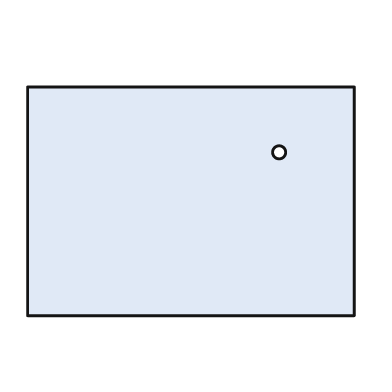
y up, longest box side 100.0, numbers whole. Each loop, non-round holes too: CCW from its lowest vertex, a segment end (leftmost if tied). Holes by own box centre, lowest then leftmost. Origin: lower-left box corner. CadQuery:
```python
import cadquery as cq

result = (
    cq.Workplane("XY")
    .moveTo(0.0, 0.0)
    .lineTo(100.0, 0.0)
    .lineTo(100.0, 70.0)
    .lineTo(0.0, 70.0)
    .close()
    .moveTo(77.0, 50.0)
    .circle(2.0)
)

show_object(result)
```